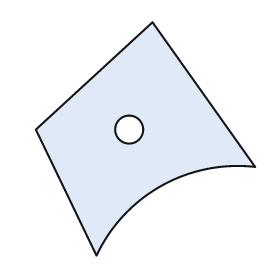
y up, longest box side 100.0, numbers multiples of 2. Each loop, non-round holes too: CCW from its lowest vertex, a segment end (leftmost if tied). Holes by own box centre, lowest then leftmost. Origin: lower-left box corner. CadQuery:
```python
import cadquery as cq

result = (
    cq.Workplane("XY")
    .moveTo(26.0, 0.0)
    .threePointArc((54.0, 30.0), (94.0, 38.0))
    .lineTo(50.0, 100.0)
    .lineTo(0.0, 54.0)
    .close()
    .moveTo(40.0, 54.0)
    .circle(6.0)
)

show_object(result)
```